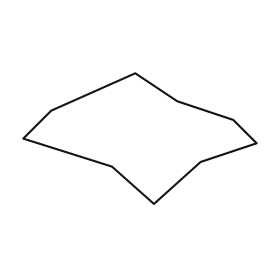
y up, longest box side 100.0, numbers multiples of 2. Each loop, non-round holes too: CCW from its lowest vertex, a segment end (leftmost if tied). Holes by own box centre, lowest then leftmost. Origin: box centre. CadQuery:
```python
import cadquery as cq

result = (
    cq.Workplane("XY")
    .moveTo(6.0, -28.0)
    .lineTo(26.0, -10.0)
    .lineTo(50.0, -2.0)
    .lineTo(40.0, 8.0)
    .lineTo(16.0, 16.0)
    .lineTo(-2.0, 28.0)
    .lineTo(-38.0, 12.0)
    .lineTo(-50.0, 0.0)
    .lineTo(-12.0, -12.0)
    .close()
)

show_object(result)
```